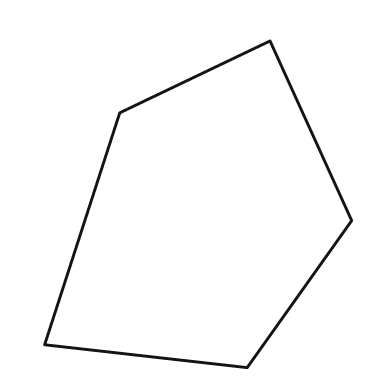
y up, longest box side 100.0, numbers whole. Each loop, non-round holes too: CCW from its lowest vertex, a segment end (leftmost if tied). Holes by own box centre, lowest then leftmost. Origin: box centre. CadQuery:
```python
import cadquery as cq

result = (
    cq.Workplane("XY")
    .moveTo(15.0, -50.0)
    .lineTo(47.0, -5.0)
    .lineTo(22.0, 50.0)
    .lineTo(-24.0, 28.0)
    .lineTo(-47.0, -43.0)
    .close()
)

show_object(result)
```